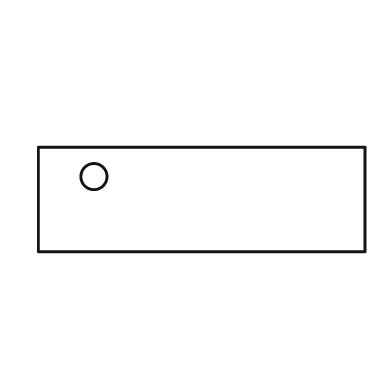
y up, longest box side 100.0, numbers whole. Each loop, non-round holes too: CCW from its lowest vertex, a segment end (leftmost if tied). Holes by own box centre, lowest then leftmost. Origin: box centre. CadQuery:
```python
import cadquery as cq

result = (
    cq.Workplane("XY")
    .moveTo(-50.0, -16.0)
    .lineTo(50.0, -16.0)
    .lineTo(50.0, 16.0)
    .lineTo(-50.0, 16.0)
    .close()
    .moveTo(-33.0, 7.0)
    .circle(4.0)
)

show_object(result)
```